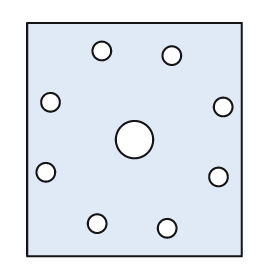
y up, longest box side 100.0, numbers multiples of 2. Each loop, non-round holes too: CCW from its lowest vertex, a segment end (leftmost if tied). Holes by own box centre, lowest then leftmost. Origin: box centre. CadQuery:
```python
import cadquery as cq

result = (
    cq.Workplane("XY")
    .moveTo(-46.0, -50.0)
    .lineTo(46.0, -50.0)
    .lineTo(46.0, 50.0)
    .lineTo(-46.0, 50.0)
    .close()
    .moveTo(14.0, -38.0)
    .circle(4.0)
    .moveTo(-16.0, -36.0)
    .circle(4.0)
    .moveTo(36.0, -16.0)
    .circle(4.0)
    .moveTo(-38.0, -14.0)
    .circle(4.0)
    .moveTo(0.0, 0.0)
    .circle(8.0)
    .moveTo(38.0, 14.0)
    .circle(4.0)
    .moveTo(-36.0, 16.0)
    .circle(4.0)
    .moveTo(16.0, 36.0)
    .circle(4.0)
    .moveTo(-14.0, 38.0)
    .circle(4.0)
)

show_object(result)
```